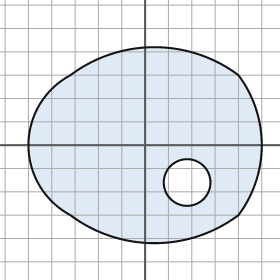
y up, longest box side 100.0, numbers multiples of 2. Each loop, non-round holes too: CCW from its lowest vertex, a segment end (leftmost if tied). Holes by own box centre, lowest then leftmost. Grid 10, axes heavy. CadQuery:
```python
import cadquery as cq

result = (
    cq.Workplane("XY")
    .moveTo(-32.0, -30.0)
    .threePointArc((4.0, -42.0), (40.0, -30.0))
    .threePointArc((50.0, 0.0), (40.0, 30.0))
    .threePointArc((4.0, 42.0), (-32.0, 30.0))
    .threePointArc((-50.0, 0.0), (-32.0, -30.0))
    .close()
    .moveTo(18.0, -16.0)
    .circle(10.0)
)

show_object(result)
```